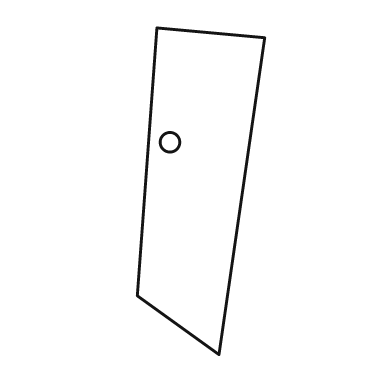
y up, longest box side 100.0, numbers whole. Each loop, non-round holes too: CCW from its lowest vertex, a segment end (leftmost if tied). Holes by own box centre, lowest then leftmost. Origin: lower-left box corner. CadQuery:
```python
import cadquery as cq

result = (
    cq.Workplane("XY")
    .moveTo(25.0, 0.0)
    .lineTo(39.0, 97.0)
    .lineTo(6.0, 100.0)
    .lineTo(0.0, 18.0)
    .close()
    .moveTo(10.0, 65.0)
    .circle(3.0)
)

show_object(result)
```